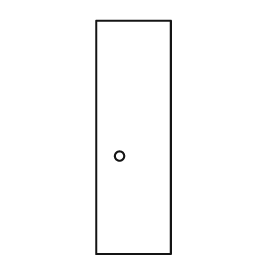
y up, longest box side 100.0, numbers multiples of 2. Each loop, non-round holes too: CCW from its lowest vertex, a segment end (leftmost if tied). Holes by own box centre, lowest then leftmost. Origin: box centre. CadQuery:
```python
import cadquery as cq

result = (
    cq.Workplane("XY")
    .moveTo(-16.0, -50.0)
    .lineTo(16.0, -50.0)
    .lineTo(16.0, 50.0)
    .lineTo(-16.0, 50.0)
    .close()
    .moveTo(-6.0, -8.0)
    .circle(2.0)
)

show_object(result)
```